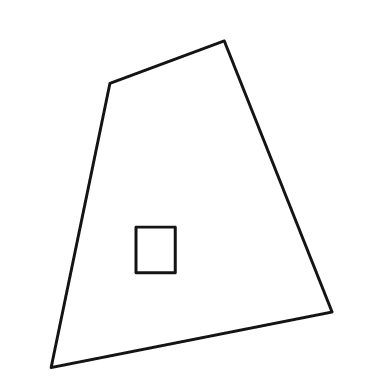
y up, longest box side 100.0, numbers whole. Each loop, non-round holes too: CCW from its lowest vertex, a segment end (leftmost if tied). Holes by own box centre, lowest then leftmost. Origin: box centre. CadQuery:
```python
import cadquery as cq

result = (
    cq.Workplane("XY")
    .moveTo(-43.0, -50.0)
    .lineTo(43.0, -33.0)
    .lineTo(10.0, 50.0)
    .lineTo(-25.0, 37.0)
    .close()
    .moveTo(-17.0, -21.0)
    .lineTo(-5.0, -21.0)
    .lineTo(-5.0, -7.0)
    .lineTo(-17.0, -7.0)
    .close()
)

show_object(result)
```